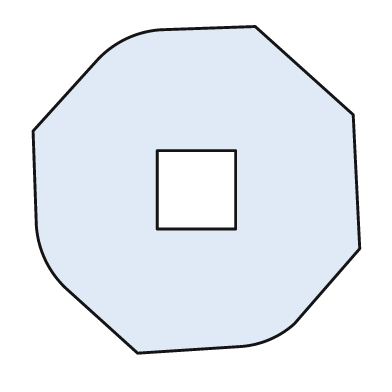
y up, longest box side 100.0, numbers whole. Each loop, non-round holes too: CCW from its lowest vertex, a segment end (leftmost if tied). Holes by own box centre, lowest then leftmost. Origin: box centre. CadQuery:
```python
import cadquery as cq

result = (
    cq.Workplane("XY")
    .moveTo(-18.0, -50.0)
    .lineTo(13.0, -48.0)
    .threePointArc((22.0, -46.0), (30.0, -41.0))
    .lineTo(50.0, -18.0)
    .lineTo(48.0, 23.0)
    .lineTo(18.0, 50.0)
    .lineTo(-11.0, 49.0)
    .threePointArc((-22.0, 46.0), (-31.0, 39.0))
    .lineTo(-50.0, 18.0)
    .lineTo(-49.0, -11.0)
    .threePointArc((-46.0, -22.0), (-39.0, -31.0))
    .close()
    .moveTo(-12.0, -12.0)
    .lineTo(12.0, -12.0)
    .lineTo(12.0, 12.0)
    .lineTo(-12.0, 12.0)
    .close()
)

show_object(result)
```